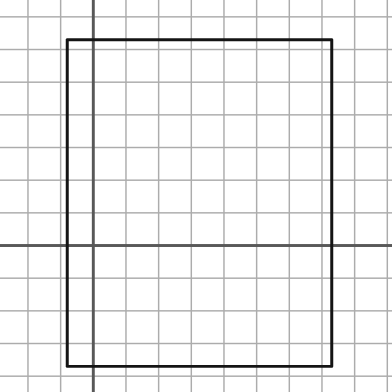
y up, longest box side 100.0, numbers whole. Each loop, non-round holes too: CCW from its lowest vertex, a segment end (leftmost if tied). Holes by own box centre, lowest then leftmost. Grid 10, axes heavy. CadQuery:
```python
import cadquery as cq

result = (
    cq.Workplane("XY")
    .moveTo(-8.0, -37.0)
    .lineTo(73.0, -37.0)
    .lineTo(73.0, 63.0)
    .lineTo(-8.0, 63.0)
    .close()
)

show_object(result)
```